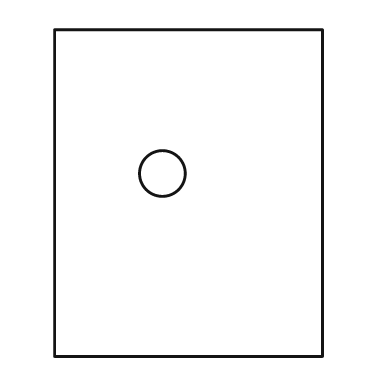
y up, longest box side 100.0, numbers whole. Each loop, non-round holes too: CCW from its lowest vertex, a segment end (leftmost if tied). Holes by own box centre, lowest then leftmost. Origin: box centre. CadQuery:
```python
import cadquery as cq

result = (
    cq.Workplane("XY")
    .moveTo(-41.0, -50.0)
    .lineTo(41.0, -50.0)
    .lineTo(41.0, 50.0)
    .lineTo(-41.0, 50.0)
    .close()
    .moveTo(-8.0, 6.0)
    .circle(7.0)
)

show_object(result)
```